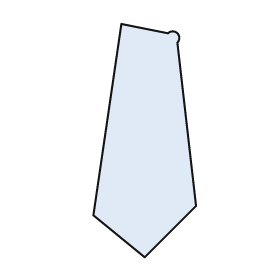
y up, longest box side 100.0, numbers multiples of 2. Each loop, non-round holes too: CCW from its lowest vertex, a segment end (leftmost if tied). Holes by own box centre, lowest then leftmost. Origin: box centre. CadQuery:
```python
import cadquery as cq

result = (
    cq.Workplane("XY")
    .moveTo(0.0, -50.0)
    .lineTo(22.0, -28.0)
    .lineTo(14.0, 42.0)
    .threePointArc((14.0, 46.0), (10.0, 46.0))
    .lineTo(-10.0, 50.0)
    .lineTo(-22.0, -32.0)
    .close()
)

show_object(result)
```